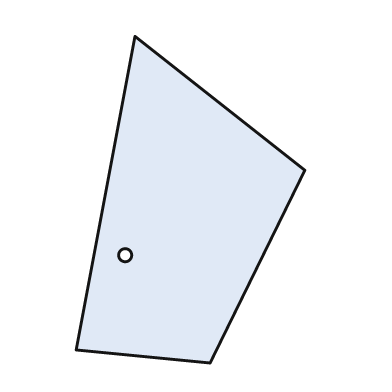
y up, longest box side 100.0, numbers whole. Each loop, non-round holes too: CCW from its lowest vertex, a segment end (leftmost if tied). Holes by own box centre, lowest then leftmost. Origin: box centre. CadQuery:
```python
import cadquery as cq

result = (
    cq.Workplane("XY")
    .moveTo(6.0, -50.0)
    .lineTo(35.0, 9.0)
    .lineTo(-17.0, 50.0)
    .lineTo(-35.0, -46.0)
    .close()
    .moveTo(-20.0, -17.0)
    .circle(2.0)
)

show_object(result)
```